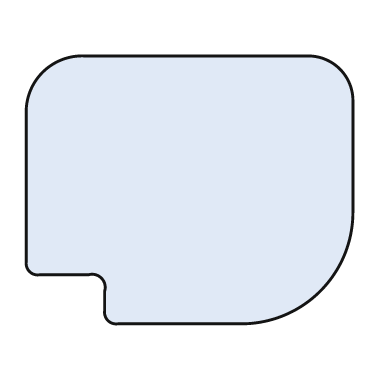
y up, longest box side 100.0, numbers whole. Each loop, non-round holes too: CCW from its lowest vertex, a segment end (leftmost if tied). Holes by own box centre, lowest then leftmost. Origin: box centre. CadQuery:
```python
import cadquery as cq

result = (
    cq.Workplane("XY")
    .moveTo(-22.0, -41.0)
    .lineTo(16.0, -41.0)
    .threePointArc((40.0, -31.0), (50.0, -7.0))
    .lineTo(50.0, 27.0)
    .threePointArc((46.0, 37.0), (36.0, 41.0))
    .lineTo(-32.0, 41.0)
    .threePointArc((-45.0, 36.0), (-50.0, 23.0))
    .lineTo(-50.0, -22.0)
    .threePointArc((-49.0, -25.0), (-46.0, -26.0))
    .lineTo(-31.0, -26.0)
    .threePointArc((-27.0, -27.0), (-26.0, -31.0))
    .lineTo(-26.0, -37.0)
    .threePointArc((-25.0, -40.0), (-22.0, -41.0))
    .close()
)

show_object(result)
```